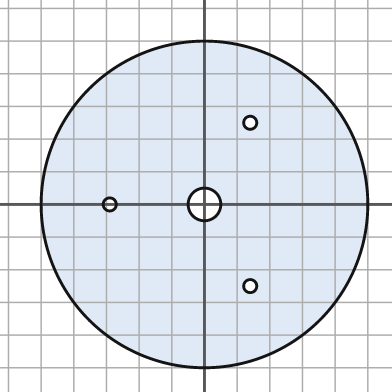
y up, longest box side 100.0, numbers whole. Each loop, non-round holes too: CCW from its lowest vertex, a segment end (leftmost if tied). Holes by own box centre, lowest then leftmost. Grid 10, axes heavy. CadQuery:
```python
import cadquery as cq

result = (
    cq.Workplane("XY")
    .moveTo(0.0, 0.0)
    .circle(50.0)
    .moveTo(14.0, -25.0)
    .circle(2.0)
    .moveTo(-29.0, 0.0)
    .circle(2.0)
    .moveTo(0.0, 0.0)
    .circle(5.0)
    .moveTo(14.0, 25.0)
    .circle(2.0)
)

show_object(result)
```